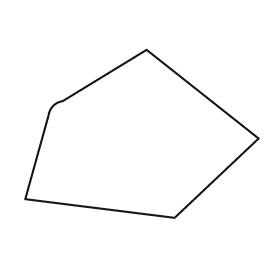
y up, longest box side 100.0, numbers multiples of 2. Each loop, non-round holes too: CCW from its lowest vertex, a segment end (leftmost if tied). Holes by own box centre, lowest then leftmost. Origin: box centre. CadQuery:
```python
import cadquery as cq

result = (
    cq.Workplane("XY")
    .moveTo(14.0, -36.0)
    .lineTo(50.0, -2.0)
    .lineTo(2.0, 36.0)
    .lineTo(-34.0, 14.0)
    .threePointArc((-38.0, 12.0), (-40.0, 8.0))
    .lineTo(-50.0, -28.0)
    .close()
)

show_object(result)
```